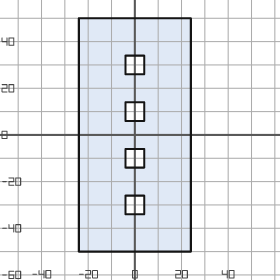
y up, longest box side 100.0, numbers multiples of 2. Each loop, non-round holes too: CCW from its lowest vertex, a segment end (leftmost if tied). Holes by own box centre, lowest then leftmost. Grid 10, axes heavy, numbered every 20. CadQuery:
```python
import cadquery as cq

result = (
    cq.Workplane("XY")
    .moveTo(-24.0, -50.0)
    .lineTo(24.0, -50.0)
    .lineTo(24.0, 50.0)
    .lineTo(-24.0, 50.0)
    .close()
    .moveTo(-4.0, -34.0)
    .lineTo(4.0, -34.0)
    .lineTo(4.0, -26.0)
    .lineTo(-4.0, -26.0)
    .close()
    .moveTo(-4.0, -14.0)
    .lineTo(4.0, -14.0)
    .lineTo(4.0, -6.0)
    .lineTo(-4.0, -6.0)
    .close()
    .moveTo(-4.0, 6.0)
    .lineTo(4.0, 6.0)
    .lineTo(4.0, 14.0)
    .lineTo(-4.0, 14.0)
    .close()
    .moveTo(-4.0, 26.0)
    .lineTo(4.0, 26.0)
    .lineTo(4.0, 34.0)
    .lineTo(-4.0, 34.0)
    .close()
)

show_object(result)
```